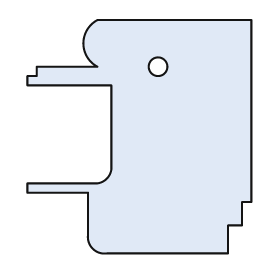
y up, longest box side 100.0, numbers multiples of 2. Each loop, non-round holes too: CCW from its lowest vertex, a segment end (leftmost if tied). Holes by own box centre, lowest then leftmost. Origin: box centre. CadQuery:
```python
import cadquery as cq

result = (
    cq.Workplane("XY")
    .moveTo(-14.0, -50.0)
    .lineTo(38.0, -50.0)
    .lineTo(38.0, -38.0)
    .lineTo(44.0, -38.0)
    .lineTo(44.0, -28.0)
    .lineTo(48.0, -28.0)
    .lineTo(48.0, 50.0)
    .lineTo(-18.0, 50.0)
    .threePointArc((-24.0, 40.0), (-18.0, 30.0))
    .lineTo(-44.0, 30.0)
    .lineTo(-44.0, 26.0)
    .lineTo(-48.0, 26.0)
    .lineTo(-48.0, 22.0)
    .lineTo(-12.0, 22.0)
    .lineTo(-12.0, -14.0)
    .threePointArc((-14.0, -18.0), (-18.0, -20.0))
    .lineTo(-48.0, -20.0)
    .lineTo(-48.0, -24.0)
    .lineTo(-22.0, -24.0)
    .lineTo(-22.0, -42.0)
    .threePointArc((-20.0, -48.0), (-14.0, -50.0))
    .close()
    .moveTo(8.0, 30.0)
    .circle(4.0)
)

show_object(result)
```